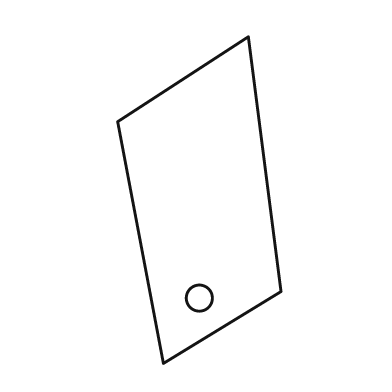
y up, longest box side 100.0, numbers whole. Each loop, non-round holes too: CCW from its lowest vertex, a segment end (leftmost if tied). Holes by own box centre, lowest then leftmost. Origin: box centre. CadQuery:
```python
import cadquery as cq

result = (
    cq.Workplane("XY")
    .moveTo(-11.0, -50.0)
    .lineTo(25.0, -28.0)
    .lineTo(15.0, 50.0)
    .lineTo(-25.0, 24.0)
    .close()
    .moveTo(0.0, -30.0)
    .circle(4.0)
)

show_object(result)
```